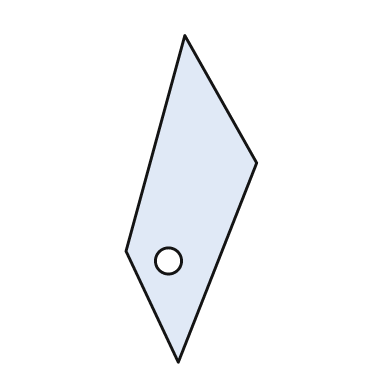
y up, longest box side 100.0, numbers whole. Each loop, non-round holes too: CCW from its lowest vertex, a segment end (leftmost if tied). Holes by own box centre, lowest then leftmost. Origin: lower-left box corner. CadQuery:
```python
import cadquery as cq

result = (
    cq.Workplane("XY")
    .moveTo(16.0, 0.0)
    .lineTo(40.0, 61.0)
    .lineTo(18.0, 100.0)
    .lineTo(0.0, 34.0)
    .close()
    .moveTo(13.0, 31.0)
    .circle(4.0)
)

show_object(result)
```